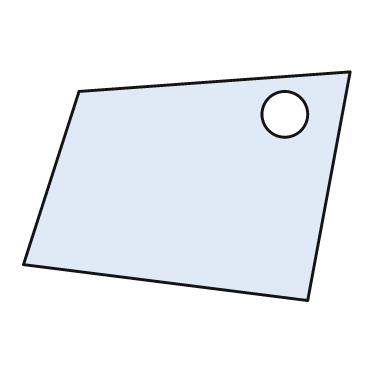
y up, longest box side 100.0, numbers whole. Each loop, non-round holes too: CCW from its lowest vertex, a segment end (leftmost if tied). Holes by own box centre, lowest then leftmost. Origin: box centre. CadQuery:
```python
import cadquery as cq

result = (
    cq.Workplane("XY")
    .moveTo(37.0, -35.0)
    .lineTo(50.0, 35.0)
    .lineTo(-33.0, 29.0)
    .lineTo(-50.0, -24.0)
    .close()
    .moveTo(30.0, 22.0)
    .circle(7.0)
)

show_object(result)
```